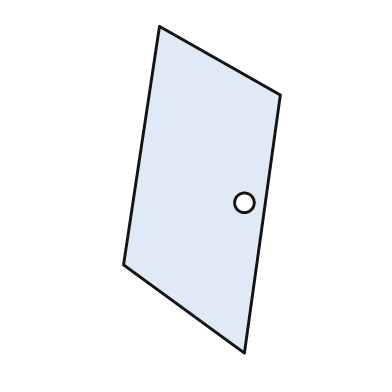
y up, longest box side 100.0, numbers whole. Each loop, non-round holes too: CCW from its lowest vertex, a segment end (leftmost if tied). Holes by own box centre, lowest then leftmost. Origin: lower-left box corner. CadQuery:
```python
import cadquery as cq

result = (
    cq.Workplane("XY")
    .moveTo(37.0, 0.0)
    .lineTo(48.0, 79.0)
    .lineTo(11.0, 100.0)
    .lineTo(0.0, 27.0)
    .close()
    .moveTo(37.0, 46.0)
    .circle(3.0)
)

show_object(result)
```